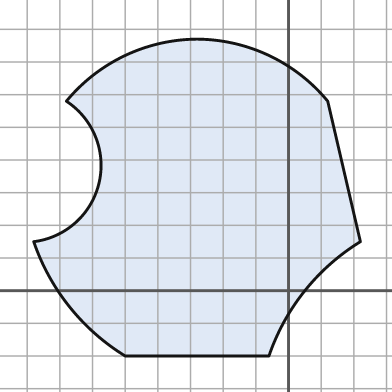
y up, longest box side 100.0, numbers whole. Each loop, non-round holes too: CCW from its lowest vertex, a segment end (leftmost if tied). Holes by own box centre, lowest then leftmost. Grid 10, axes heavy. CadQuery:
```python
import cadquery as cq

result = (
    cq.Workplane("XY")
    .moveTo(-50.0, -20.0)
    .lineTo(-6.0, -20.0)
    .threePointArc((5.0, 0.0), (22.0, 15.0))
    .lineTo(12.0, 58.0)
    .threePointArc((-6.0, 72.0), (-28.0, 77.0))
    .threePointArc((-50.0, 72.0), (-68.0, 58.0))
    .threePointArc((-58.0, 33.0), (-78.0, 15.0))
    .threePointArc((-67.0, -5.0), (-50.0, -20.0))
    .close()
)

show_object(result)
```